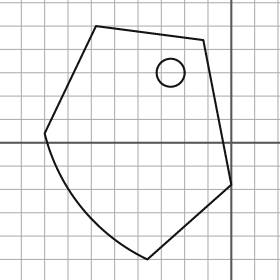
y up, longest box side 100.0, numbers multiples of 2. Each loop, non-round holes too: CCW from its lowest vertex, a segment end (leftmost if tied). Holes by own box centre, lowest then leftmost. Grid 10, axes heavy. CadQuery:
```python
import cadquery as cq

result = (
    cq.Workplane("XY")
    .moveTo(-36.0, -50.0)
    .lineTo(0.0, -18.0)
    .lineTo(-12.0, 44.0)
    .lineTo(-58.0, 50.0)
    .lineTo(-80.0, 4.0)
    .threePointArc((-64.0, -28.0), (-36.0, -50.0))
    .close()
    .moveTo(-26.0, 30.0)
    .circle(6.0)
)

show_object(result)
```